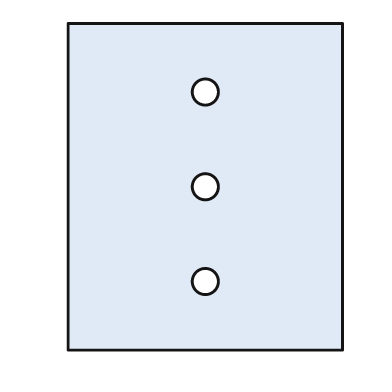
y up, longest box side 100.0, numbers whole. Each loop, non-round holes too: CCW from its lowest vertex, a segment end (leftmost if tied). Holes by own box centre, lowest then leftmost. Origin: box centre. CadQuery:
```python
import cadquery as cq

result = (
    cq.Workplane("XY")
    .moveTo(-42.0, -50.0)
    .lineTo(42.0, -50.0)
    .lineTo(42.0, 50.0)
    .lineTo(-42.0, 50.0)
    .close()
    .moveTo(0.0, -29.0)
    .circle(4.0)
    .moveTo(0.0, 0.0)
    .circle(4.0)
    .moveTo(0.0, 29.0)
    .circle(4.0)
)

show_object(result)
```